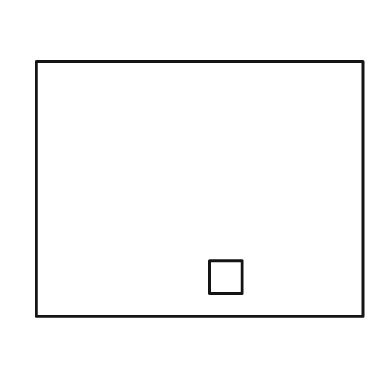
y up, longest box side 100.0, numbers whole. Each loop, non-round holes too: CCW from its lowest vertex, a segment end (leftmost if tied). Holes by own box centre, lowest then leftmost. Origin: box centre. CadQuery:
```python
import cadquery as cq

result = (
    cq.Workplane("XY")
    .moveTo(-50.0, -39.0)
    .lineTo(50.0, -39.0)
    .lineTo(50.0, 39.0)
    .lineTo(-50.0, 39.0)
    .close()
    .moveTo(3.0, -32.0)
    .lineTo(13.0, -32.0)
    .lineTo(13.0, -22.0)
    .lineTo(3.0, -22.0)
    .close()
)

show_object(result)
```